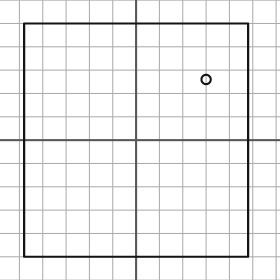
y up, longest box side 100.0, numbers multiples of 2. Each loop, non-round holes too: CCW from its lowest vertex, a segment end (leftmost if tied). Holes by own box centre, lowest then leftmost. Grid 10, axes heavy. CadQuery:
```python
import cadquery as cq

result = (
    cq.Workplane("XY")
    .moveTo(-48.0, -50.0)
    .lineTo(48.0, -50.0)
    .lineTo(48.0, 50.0)
    .lineTo(-48.0, 50.0)
    .close()
    .moveTo(30.0, 26.0)
    .circle(2.0)
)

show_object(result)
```